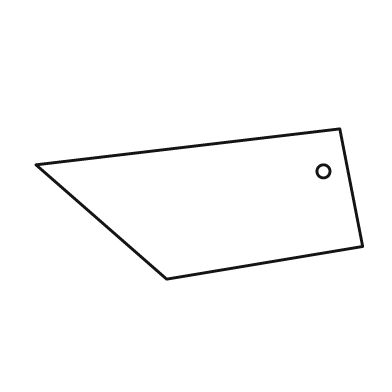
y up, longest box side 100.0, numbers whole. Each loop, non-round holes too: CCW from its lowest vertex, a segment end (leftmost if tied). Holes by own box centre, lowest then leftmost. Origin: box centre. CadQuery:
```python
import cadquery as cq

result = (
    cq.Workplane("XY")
    .moveTo(-10.0, -23.0)
    .lineTo(50.0, -13.0)
    .lineTo(43.0, 23.0)
    .lineTo(-50.0, 12.0)
    .close()
    .moveTo(38.0, 10.0)
    .circle(2.0)
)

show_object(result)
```